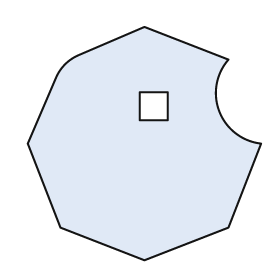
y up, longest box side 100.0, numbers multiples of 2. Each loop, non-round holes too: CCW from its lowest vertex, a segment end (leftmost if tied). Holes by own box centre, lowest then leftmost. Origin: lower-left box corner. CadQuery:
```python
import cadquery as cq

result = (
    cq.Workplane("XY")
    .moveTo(50.0, 0.0)
    .lineTo(86.0, 14.0)
    .lineTo(100.0, 50.0)
    .threePointArc((82.0, 64.0), (86.0, 86.0))
    .lineTo(50.0, 100.0)
    .lineTo(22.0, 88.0)
    .threePointArc((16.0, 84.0), (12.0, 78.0))
    .lineTo(0.0, 50.0)
    .lineTo(14.0, 14.0)
    .close()
    .moveTo(48.0, 60.0)
    .lineTo(60.0, 60.0)
    .lineTo(60.0, 72.0)
    .lineTo(48.0, 72.0)
    .close()
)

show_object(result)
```